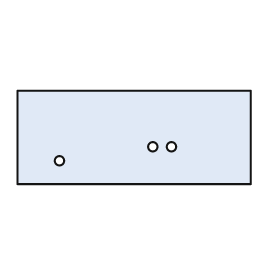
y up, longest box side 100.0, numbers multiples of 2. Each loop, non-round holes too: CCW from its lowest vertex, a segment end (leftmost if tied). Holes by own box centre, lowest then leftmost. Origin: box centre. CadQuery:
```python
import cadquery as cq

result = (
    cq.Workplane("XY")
    .moveTo(-50.0, -20.0)
    .lineTo(50.0, -20.0)
    .lineTo(50.0, 20.0)
    .lineTo(-50.0, 20.0)
    .close()
    .moveTo(-32.0, -10.0)
    .circle(2.0)
    .moveTo(8.0, -4.0)
    .circle(2.0)
    .moveTo(16.0, -4.0)
    .circle(2.0)
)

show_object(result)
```